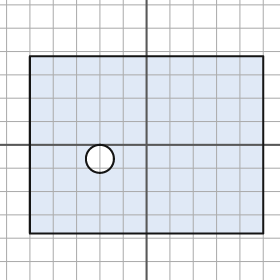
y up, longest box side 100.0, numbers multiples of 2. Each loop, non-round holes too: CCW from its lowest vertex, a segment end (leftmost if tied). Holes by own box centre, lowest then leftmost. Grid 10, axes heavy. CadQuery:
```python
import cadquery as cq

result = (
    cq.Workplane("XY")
    .moveTo(-50.0, -38.0)
    .lineTo(50.0, -38.0)
    .lineTo(50.0, 38.0)
    .lineTo(-50.0, 38.0)
    .close()
    .moveTo(-20.0, -6.0)
    .circle(6.0)
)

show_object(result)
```